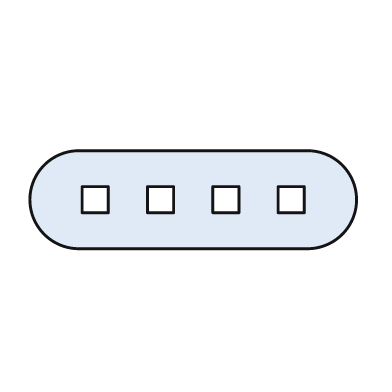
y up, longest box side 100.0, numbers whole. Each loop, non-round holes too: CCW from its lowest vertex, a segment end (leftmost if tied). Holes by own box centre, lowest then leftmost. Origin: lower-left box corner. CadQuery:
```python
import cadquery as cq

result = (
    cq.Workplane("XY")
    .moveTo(15.0, 0.0)
    .lineTo(85.0, 0.0)
    .threePointArc((100.0, 15.0), (85.0, 30.0))
    .lineTo(15.0, 30.0)
    .threePointArc((0.0, 15.0), (15.0, 0.0))
    .close()
    .moveTo(16.0, 11.0)
    .lineTo(24.0, 11.0)
    .lineTo(24.0, 19.0)
    .lineTo(16.0, 19.0)
    .close()
    .moveTo(36.0, 11.0)
    .lineTo(44.0, 11.0)
    .lineTo(44.0, 19.0)
    .lineTo(36.0, 19.0)
    .close()
    .moveTo(56.0, 11.0)
    .lineTo(64.0, 11.0)
    .lineTo(64.0, 19.0)
    .lineTo(56.0, 19.0)
    .close()
    .moveTo(76.0, 11.0)
    .lineTo(84.0, 11.0)
    .lineTo(84.0, 19.0)
    .lineTo(76.0, 19.0)
    .close()
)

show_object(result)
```